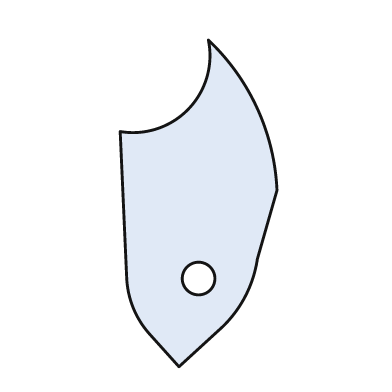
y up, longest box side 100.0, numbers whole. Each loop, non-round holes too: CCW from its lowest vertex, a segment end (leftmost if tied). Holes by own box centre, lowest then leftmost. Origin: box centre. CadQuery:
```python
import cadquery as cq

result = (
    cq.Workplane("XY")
    .moveTo(-6.0, -50.0)
    .lineTo(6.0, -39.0)
    .threePointArc((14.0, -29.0), (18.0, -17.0))
    .lineTo(24.0, 4.0)
    .threePointArc((18.0, 29.0), (3.0, 50.0))
    .threePointArc((-3.0, 29.0), (-24.0, 22.0))
    .lineTo(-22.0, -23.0)
    .threePointArc((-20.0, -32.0), (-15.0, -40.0))
    .close()
    .moveTo(0.0, -23.0)
    .circle(5.0)
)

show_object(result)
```